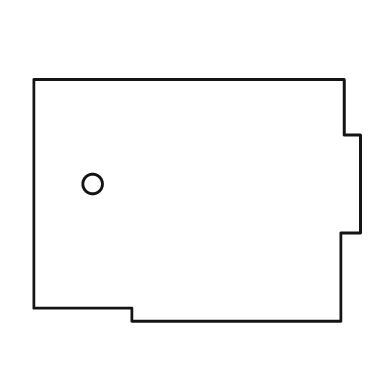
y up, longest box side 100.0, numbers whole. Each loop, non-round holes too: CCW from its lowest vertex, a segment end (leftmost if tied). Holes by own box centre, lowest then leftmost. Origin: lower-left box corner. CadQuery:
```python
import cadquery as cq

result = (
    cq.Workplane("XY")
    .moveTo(30.0, 0.0)
    .lineTo(94.0, 0.0)
    .lineTo(94.0, 27.0)
    .lineTo(100.0, 27.0)
    .lineTo(100.0, 57.0)
    .lineTo(95.0, 57.0)
    .lineTo(95.0, 74.0)
    .lineTo(0.0, 74.0)
    .lineTo(0.0, 4.0)
    .lineTo(30.0, 4.0)
    .close()
    .moveTo(18.0, 42.0)
    .circle(3.0)
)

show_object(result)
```